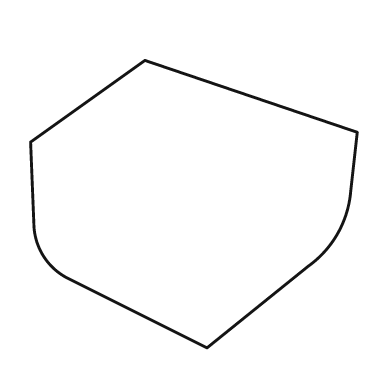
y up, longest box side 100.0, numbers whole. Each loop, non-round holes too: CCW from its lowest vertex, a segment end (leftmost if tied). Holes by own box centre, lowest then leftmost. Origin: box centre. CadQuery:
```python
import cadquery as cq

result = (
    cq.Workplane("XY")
    .moveTo(4.0, -44.0)
    .lineTo(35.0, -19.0)
    .threePointArc((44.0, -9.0), (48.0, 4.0))
    .lineTo(50.0, 22.0)
    .lineTo(-15.0, 44.0)
    .lineTo(-50.0, 19.0)
    .lineTo(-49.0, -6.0)
    .threePointArc((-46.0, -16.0), (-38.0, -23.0))
    .close()
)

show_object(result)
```